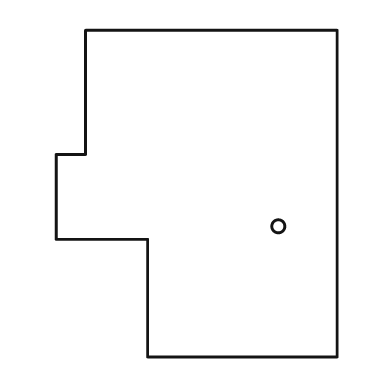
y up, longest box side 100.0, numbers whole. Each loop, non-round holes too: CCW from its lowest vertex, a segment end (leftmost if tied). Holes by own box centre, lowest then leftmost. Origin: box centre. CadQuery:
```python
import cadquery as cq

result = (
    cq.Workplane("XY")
    .moveTo(-15.0, -50.0)
    .lineTo(43.0, -50.0)
    .lineTo(43.0, 50.0)
    .lineTo(-34.0, 50.0)
    .lineTo(-34.0, 12.0)
    .lineTo(-43.0, 12.0)
    .lineTo(-43.0, -14.0)
    .lineTo(-15.0, -14.0)
    .close()
    .moveTo(25.0, -10.0)
    .circle(2.0)
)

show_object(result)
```